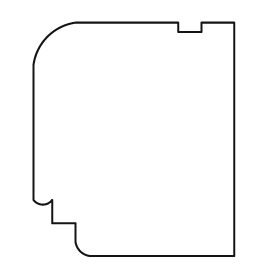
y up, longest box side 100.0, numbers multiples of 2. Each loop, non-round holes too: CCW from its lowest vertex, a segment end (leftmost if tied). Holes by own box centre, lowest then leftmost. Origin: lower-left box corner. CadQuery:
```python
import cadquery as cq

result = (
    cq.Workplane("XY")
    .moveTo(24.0, 0.0)
    .lineTo(86.0, 0.0)
    .lineTo(86.0, 100.0)
    .lineTo(72.0, 100.0)
    .lineTo(72.0, 96.0)
    .lineTo(62.0, 96.0)
    .lineTo(62.0, 100.0)
    .lineTo(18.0, 100.0)
    .threePointArc((6.0, 94.0), (0.0, 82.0))
    .lineTo(0.0, 24.0)
    .threePointArc((4.0, 22.0), (8.0, 24.0))
    .lineTo(8.0, 14.0)
    .lineTo(18.0, 14.0)
    .lineTo(18.0, 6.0)
    .threePointArc((20.0, 2.0), (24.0, 0.0))
    .close()
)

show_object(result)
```